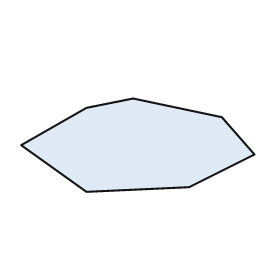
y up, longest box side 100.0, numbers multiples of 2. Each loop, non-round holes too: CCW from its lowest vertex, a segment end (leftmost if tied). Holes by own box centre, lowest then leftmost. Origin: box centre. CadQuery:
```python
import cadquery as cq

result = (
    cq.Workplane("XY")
    .moveTo(-22.0, -20.0)
    .lineTo(22.0, -18.0)
    .lineTo(50.0, -4.0)
    .lineTo(36.0, 12.0)
    .lineTo(-2.0, 20.0)
    .lineTo(-22.0, 16.0)
    .lineTo(-50.0, 0.0)
    .close()
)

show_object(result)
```